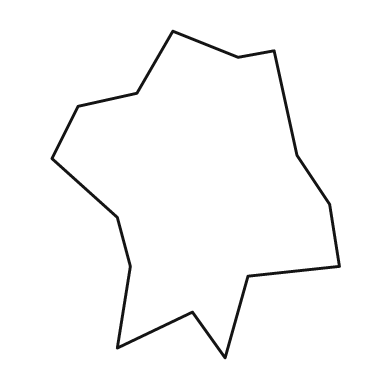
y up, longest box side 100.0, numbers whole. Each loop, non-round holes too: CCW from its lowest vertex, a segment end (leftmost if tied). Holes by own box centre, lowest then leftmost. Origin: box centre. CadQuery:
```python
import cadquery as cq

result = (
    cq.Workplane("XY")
    .moveTo(9.0, -50.0)
    .lineTo(16.0, -25.0)
    .lineTo(44.0, -22.0)
    .lineTo(41.0, -3.0)
    .lineTo(31.0, 12.0)
    .lineTo(24.0, 44.0)
    .lineTo(13.0, 42.0)
    .lineTo(-7.0, 50.0)
    .lineTo(-18.0, 31.0)
    .lineTo(-36.0, 27.0)
    .lineTo(-44.0, 11.0)
    .lineTo(-24.0, -7.0)
    .lineTo(-20.0, -22.0)
    .lineTo(-24.0, -47.0)
    .lineTo(-1.0, -36.0)
    .close()
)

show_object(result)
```